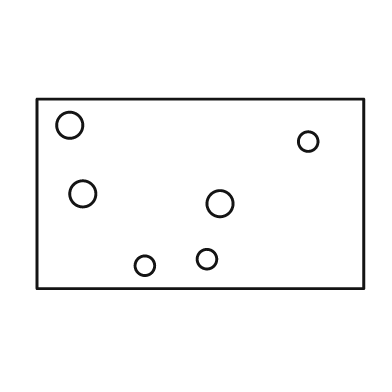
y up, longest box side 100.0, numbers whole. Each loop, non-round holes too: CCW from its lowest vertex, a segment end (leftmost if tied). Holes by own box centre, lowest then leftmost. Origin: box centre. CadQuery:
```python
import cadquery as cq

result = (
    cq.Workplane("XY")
    .moveTo(-50.0, -29.0)
    .lineTo(50.0, -29.0)
    .lineTo(50.0, 29.0)
    .lineTo(-50.0, 29.0)
    .close()
    .moveTo(-17.0, -22.0)
    .circle(3.0)
    .moveTo(2.0, -20.0)
    .circle(3.0)
    .moveTo(6.0, -3.0)
    .circle(4.0)
    .moveTo(-36.0, 0.0)
    .circle(4.0)
    .moveTo(33.0, 16.0)
    .circle(3.0)
    .moveTo(-40.0, 21.0)
    .circle(4.0)
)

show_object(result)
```